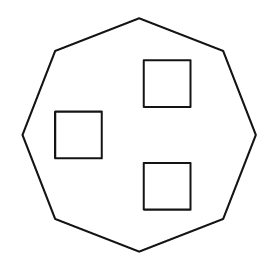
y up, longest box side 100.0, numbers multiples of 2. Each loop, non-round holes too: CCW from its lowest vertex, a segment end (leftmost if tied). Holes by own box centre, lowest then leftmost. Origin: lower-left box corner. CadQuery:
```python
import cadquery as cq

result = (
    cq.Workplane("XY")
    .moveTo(50.0, 0.0)
    .lineTo(86.0, 14.0)
    .lineTo(100.0, 50.0)
    .lineTo(86.0, 86.0)
    .lineTo(50.0, 100.0)
    .lineTo(14.0, 86.0)
    .lineTo(0.0, 50.0)
    .lineTo(14.0, 14.0)
    .close()
    .moveTo(52.0, 18.0)
    .lineTo(72.0, 18.0)
    .lineTo(72.0, 38.0)
    .lineTo(52.0, 38.0)
    .close()
    .moveTo(14.0, 40.0)
    .lineTo(34.0, 40.0)
    .lineTo(34.0, 60.0)
    .lineTo(14.0, 60.0)
    .close()
    .moveTo(52.0, 62.0)
    .lineTo(72.0, 62.0)
    .lineTo(72.0, 82.0)
    .lineTo(52.0, 82.0)
    .close()
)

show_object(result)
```